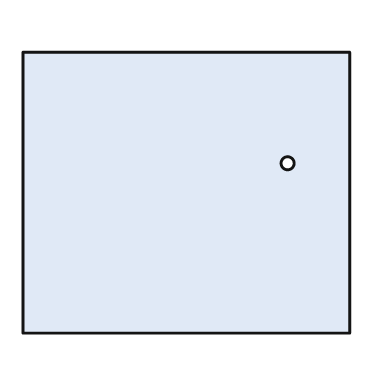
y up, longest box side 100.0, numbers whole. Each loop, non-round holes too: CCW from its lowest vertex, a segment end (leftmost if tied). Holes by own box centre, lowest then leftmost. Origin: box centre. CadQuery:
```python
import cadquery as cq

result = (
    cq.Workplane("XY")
    .moveTo(-50.0, -43.0)
    .lineTo(50.0, -43.0)
    .lineTo(50.0, 43.0)
    .lineTo(-50.0, 43.0)
    .close()
    .moveTo(31.0, 9.0)
    .circle(2.0)
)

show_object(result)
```